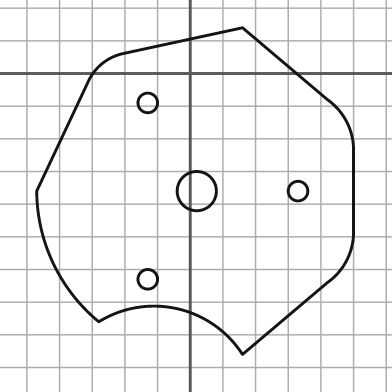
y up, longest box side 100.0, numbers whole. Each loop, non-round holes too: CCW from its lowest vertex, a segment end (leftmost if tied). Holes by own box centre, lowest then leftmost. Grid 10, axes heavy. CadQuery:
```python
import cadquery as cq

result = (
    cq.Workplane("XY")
    .moveTo(16.0, -86.0)
    .lineTo(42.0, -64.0)
    .threePointArc((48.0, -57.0), (50.0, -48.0))
    .lineTo(50.0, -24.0)
    .threePointArc((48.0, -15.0), (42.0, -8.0))
    .lineTo(16.0, 14.0)
    .lineTo(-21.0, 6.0)
    .threePointArc((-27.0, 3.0), (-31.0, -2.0))
    .lineTo(-47.0, -36.0)
    .threePointArc((-42.0, -58.0), (-28.0, -76.0))
    .threePointArc((-4.0, -72.0), (16.0, -86.0))
    .close()
    .moveTo(-13.0, -63.0)
    .circle(3.0)
    .moveTo(2.0, -36.0)
    .circle(6.0)
    .moveTo(33.0, -36.0)
    .circle(3.0)
    .moveTo(-13.0, -9.0)
    .circle(3.0)
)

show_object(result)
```